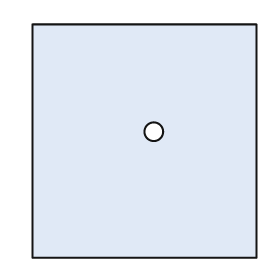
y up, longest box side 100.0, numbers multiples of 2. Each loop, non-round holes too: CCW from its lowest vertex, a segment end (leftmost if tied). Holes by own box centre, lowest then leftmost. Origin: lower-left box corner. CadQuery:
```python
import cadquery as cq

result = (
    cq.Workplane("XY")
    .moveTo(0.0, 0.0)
    .lineTo(96.0, 0.0)
    .lineTo(96.0, 100.0)
    .lineTo(0.0, 100.0)
    .close()
    .moveTo(52.0, 54.0)
    .circle(4.0)
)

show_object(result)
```